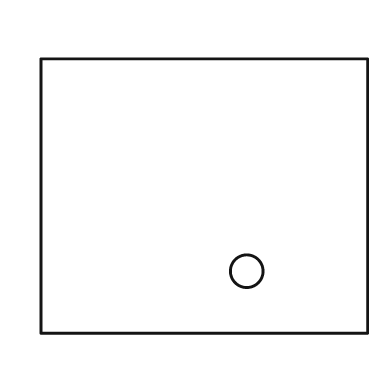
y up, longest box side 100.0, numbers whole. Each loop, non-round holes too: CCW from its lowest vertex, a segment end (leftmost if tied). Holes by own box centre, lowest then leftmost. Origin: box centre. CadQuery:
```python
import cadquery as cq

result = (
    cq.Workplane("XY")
    .moveTo(-50.0, -42.0)
    .lineTo(50.0, -42.0)
    .lineTo(50.0, 42.0)
    .lineTo(-50.0, 42.0)
    .close()
    .moveTo(13.0, -23.0)
    .circle(5.0)
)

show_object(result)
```